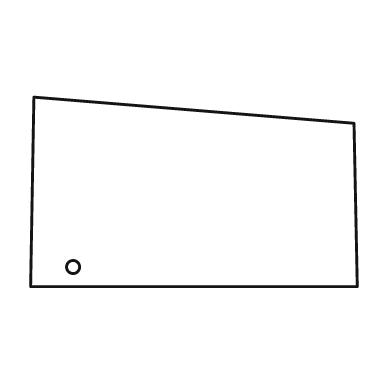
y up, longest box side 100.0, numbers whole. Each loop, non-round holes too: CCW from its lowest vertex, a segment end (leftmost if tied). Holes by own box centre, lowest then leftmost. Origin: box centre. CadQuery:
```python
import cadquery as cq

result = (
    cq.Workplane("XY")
    .moveTo(-50.0, -29.0)
    .lineTo(50.0, -29.0)
    .lineTo(49.0, 21.0)
    .lineTo(-49.0, 29.0)
    .close()
    .moveTo(-37.0, -23.0)
    .circle(2.0)
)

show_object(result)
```